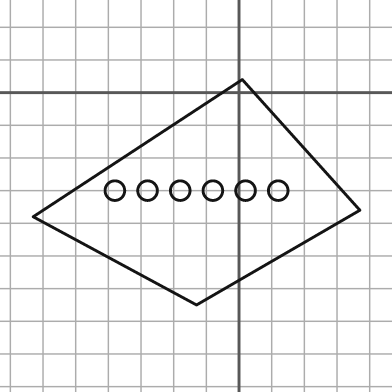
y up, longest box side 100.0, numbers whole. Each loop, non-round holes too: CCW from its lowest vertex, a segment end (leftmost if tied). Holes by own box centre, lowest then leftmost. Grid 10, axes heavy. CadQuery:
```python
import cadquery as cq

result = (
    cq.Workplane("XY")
    .moveTo(-13.0, -65.0)
    .lineTo(37.0, -36.0)
    .lineTo(1.0, 4.0)
    .lineTo(-63.0, -38.0)
    .close()
    .moveTo(-38.0, -30.0)
    .circle(3.0)
    .moveTo(-28.0, -30.0)
    .circle(3.0)
    .moveTo(-18.0, -30.0)
    .circle(3.0)
    .moveTo(-8.0, -30.0)
    .circle(3.0)
    .moveTo(2.0, -30.0)
    .circle(3.0)
    .moveTo(12.0, -30.0)
    .circle(3.0)
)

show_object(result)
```